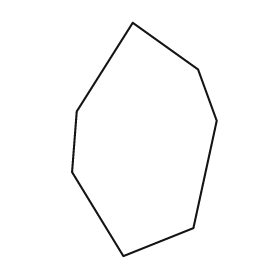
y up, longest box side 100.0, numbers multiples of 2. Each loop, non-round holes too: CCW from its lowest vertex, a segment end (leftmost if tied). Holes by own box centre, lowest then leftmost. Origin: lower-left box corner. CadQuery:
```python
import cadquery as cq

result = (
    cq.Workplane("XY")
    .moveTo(22.0, 0.0)
    .lineTo(52.0, 12.0)
    .lineTo(62.0, 58.0)
    .lineTo(54.0, 80.0)
    .lineTo(26.0, 100.0)
    .lineTo(2.0, 62.0)
    .lineTo(0.0, 36.0)
    .close()
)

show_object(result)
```